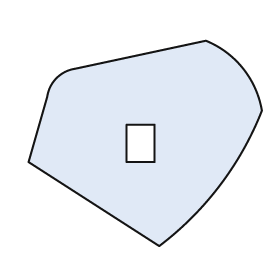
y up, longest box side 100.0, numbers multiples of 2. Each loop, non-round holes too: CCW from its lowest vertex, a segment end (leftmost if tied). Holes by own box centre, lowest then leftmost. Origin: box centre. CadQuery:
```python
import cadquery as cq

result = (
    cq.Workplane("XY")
    .moveTo(6.0, -44.0)
    .threePointArc((32.0, -18.0), (50.0, 14.0))
    .threePointArc((42.0, 32.0), (26.0, 44.0))
    .lineTo(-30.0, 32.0)
    .threePointArc((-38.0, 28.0), (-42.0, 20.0))
    .lineTo(-50.0, -8.0)
    .close()
    .moveTo(-8.0, -8.0)
    .lineTo(4.0, -8.0)
    .lineTo(4.0, 8.0)
    .lineTo(-8.0, 8.0)
    .close()
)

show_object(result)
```